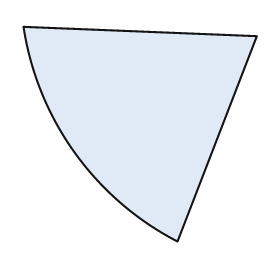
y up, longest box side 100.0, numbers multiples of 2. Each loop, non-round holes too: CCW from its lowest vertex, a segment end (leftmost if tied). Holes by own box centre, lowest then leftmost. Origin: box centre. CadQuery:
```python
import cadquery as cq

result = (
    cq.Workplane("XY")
    .moveTo(16.0, -46.0)
    .lineTo(50.0, 42.0)
    .lineTo(-50.0, 46.0)
    .threePointArc((-28.0, -8.0), (16.0, -46.0))
    .close()
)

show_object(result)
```